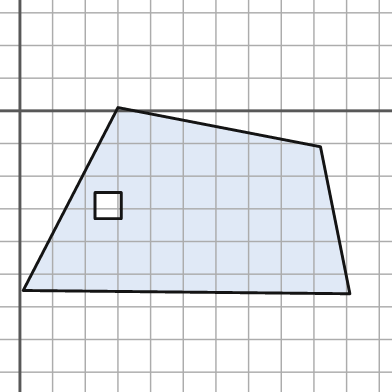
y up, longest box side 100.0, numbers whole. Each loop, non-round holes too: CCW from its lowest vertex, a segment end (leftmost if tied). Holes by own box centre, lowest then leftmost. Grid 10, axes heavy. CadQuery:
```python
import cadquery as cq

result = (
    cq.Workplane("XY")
    .moveTo(101.0, -56.0)
    .lineTo(92.0, -11.0)
    .lineTo(30.0, 1.0)
    .lineTo(1.0, -55.0)
    .close()
    .moveTo(23.0, -33.0)
    .lineTo(31.0, -33.0)
    .lineTo(31.0, -25.0)
    .lineTo(23.0, -25.0)
    .close()
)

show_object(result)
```